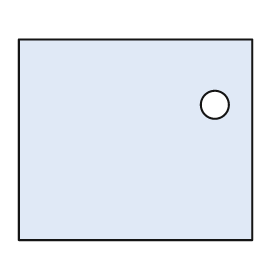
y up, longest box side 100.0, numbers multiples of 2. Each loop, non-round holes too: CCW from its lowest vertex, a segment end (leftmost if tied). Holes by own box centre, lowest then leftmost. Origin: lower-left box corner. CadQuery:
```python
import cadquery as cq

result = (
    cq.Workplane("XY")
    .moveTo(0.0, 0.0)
    .lineTo(100.0, 0.0)
    .lineTo(100.0, 86.0)
    .lineTo(0.0, 86.0)
    .close()
    .moveTo(84.0, 58.0)
    .circle(6.0)
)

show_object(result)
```